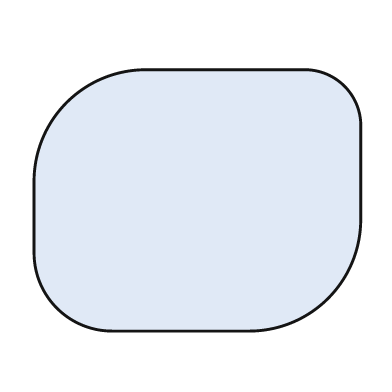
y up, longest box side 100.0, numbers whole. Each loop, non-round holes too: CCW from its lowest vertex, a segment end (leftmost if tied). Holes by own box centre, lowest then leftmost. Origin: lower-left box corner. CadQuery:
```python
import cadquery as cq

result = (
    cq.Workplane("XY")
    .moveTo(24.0, 0.0)
    .lineTo(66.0, 0.0)
    .threePointArc((90.0, 10.0), (100.0, 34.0))
    .lineTo(100.0, 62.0)
    .threePointArc((95.0, 75.0), (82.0, 80.0))
    .lineTo(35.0, 80.0)
    .threePointArc((10.0, 70.0), (0.0, 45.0))
    .lineTo(0.0, 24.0)
    .threePointArc((7.0, 7.0), (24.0, 0.0))
    .close()
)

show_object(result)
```